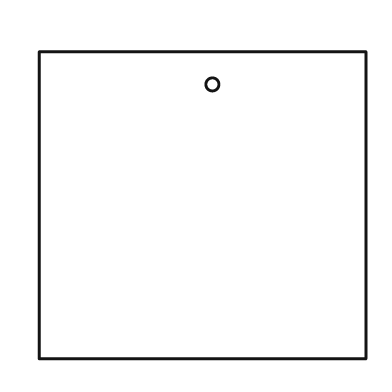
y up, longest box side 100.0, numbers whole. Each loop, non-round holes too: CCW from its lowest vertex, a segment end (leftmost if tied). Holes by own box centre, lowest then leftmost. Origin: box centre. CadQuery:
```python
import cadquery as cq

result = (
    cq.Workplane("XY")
    .moveTo(-50.0, -47.0)
    .lineTo(50.0, -47.0)
    .lineTo(50.0, 47.0)
    .lineTo(-50.0, 47.0)
    .close()
    .moveTo(3.0, 37.0)
    .circle(2.0)
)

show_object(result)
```